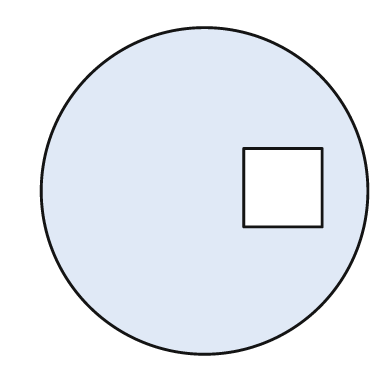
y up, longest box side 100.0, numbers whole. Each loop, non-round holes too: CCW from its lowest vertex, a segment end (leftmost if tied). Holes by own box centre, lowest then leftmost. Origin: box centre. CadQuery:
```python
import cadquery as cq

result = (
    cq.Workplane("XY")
    .moveTo(0.0, 0.0)
    .circle(50.0)
    .moveTo(12.0, -11.0)
    .lineTo(36.0, -11.0)
    .lineTo(36.0, 13.0)
    .lineTo(12.0, 13.0)
    .close()
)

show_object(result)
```